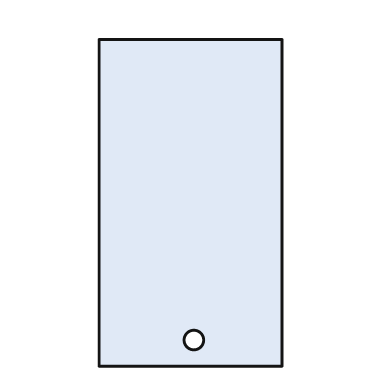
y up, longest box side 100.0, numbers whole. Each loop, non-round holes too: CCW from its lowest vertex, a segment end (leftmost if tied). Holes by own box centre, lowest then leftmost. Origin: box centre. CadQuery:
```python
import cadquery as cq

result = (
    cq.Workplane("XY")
    .moveTo(-28.0, -50.0)
    .lineTo(28.0, -50.0)
    .lineTo(28.0, 50.0)
    .lineTo(-28.0, 50.0)
    .close()
    .moveTo(1.0, -42.0)
    .circle(3.0)
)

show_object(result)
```